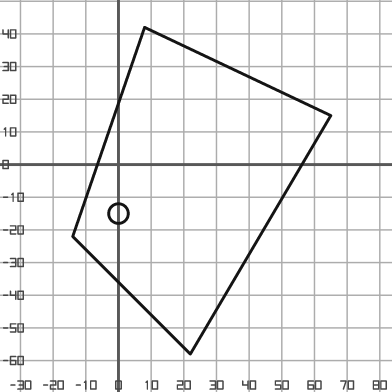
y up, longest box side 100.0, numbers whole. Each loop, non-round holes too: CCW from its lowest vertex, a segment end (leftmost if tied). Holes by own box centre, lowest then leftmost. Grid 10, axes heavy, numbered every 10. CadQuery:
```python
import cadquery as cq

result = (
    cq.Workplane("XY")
    .moveTo(22.0, -58.0)
    .lineTo(65.0, 15.0)
    .lineTo(8.0, 42.0)
    .lineTo(-14.0, -22.0)
    .close()
    .moveTo(0.0, -15.0)
    .circle(3.0)
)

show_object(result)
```